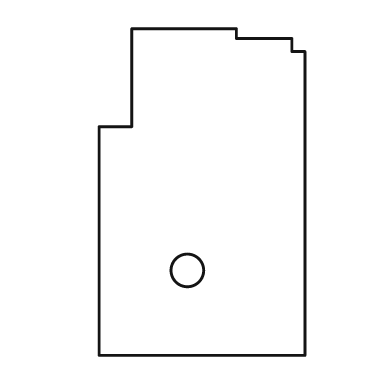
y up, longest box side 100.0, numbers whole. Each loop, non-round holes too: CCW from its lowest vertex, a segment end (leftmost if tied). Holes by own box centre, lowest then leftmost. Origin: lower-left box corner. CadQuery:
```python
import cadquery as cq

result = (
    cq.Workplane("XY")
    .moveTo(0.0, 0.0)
    .lineTo(63.0, 0.0)
    .lineTo(63.0, 93.0)
    .lineTo(59.0, 93.0)
    .lineTo(59.0, 97.0)
    .lineTo(42.0, 97.0)
    .lineTo(42.0, 100.0)
    .lineTo(10.0, 100.0)
    .lineTo(10.0, 70.0)
    .lineTo(0.0, 70.0)
    .close()
    .moveTo(27.0, 26.0)
    .circle(5.0)
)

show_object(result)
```